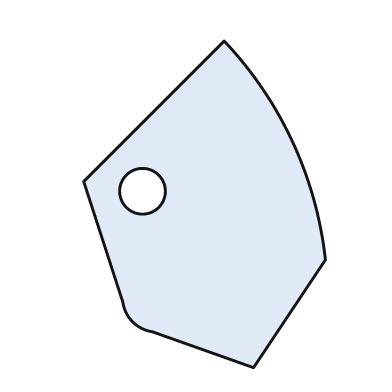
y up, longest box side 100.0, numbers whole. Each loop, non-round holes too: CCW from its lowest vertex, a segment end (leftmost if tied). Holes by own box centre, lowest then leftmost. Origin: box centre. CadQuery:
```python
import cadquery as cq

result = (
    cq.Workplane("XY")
    .moveTo(15.0, -50.0)
    .lineTo(37.0, -17.0)
    .threePointArc((27.0, 19.0), (6.0, 50.0))
    .lineTo(-37.0, 7.0)
    .lineTo(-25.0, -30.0)
    .threePointArc((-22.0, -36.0), (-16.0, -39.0))
    .close()
    .moveTo(-19.0, 4.0)
    .circle(7.0)
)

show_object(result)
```